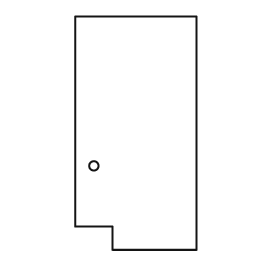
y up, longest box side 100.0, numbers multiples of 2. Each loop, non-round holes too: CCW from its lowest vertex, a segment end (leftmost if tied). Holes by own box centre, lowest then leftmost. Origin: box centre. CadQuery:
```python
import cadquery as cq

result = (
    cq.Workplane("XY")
    .moveTo(-10.0, -50.0)
    .lineTo(26.0, -50.0)
    .lineTo(26.0, 50.0)
    .lineTo(-26.0, 50.0)
    .lineTo(-26.0, -40.0)
    .lineTo(-10.0, -40.0)
    .close()
    .moveTo(-18.0, -14.0)
    .circle(2.0)
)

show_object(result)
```